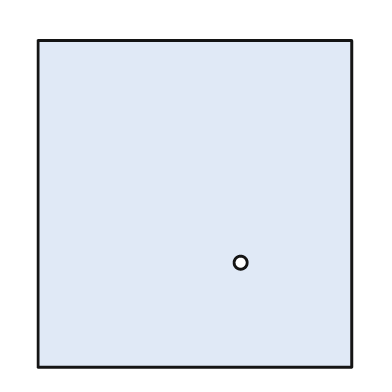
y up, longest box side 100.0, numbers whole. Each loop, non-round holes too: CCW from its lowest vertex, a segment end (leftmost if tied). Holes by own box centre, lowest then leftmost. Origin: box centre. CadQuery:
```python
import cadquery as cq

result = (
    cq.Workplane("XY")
    .moveTo(-48.0, -50.0)
    .lineTo(48.0, -50.0)
    .lineTo(48.0, 50.0)
    .lineTo(-48.0, 50.0)
    .close()
    .moveTo(14.0, -18.0)
    .circle(2.0)
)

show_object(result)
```